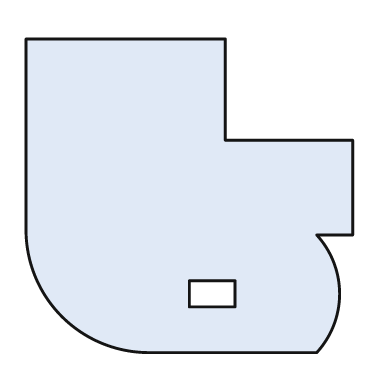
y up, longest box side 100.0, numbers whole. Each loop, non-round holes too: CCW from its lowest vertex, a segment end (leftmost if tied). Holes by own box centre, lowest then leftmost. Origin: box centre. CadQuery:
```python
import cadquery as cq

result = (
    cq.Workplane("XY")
    .moveTo(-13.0, -48.0)
    .lineTo(39.0, -48.0)
    .threePointArc((46.0, -30.0), (39.0, -12.0))
    .lineTo(50.0, -12.0)
    .lineTo(50.0, 17.0)
    .lineTo(11.0, 17.0)
    .lineTo(11.0, 48.0)
    .lineTo(-50.0, 48.0)
    .lineTo(-50.0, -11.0)
    .threePointArc((-39.0, -37.0), (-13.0, -48.0))
    .close()
    .moveTo(0.0, -34.0)
    .lineTo(14.0, -34.0)
    .lineTo(14.0, -26.0)
    .lineTo(0.0, -26.0)
    .close()
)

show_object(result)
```